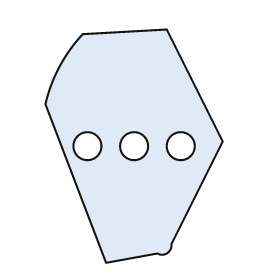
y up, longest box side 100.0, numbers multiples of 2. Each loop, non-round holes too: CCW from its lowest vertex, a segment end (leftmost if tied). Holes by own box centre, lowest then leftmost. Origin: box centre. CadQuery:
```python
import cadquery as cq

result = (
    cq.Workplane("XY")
    .moveTo(-12.0, -50.0)
    .lineTo(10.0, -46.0)
    .threePointArc((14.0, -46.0), (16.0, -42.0))
    .lineTo(38.0, 2.0)
    .lineTo(14.0, 50.0)
    .lineTo(-22.0, 48.0)
    .threePointArc((-32.0, 34.0), (-38.0, 18.0))
    .close()
    .moveTo(-20.0, 0.0)
    .circle(6.0)
    .moveTo(0.0, 0.0)
    .circle(6.0)
    .moveTo(20.0, 0.0)
    .circle(6.0)
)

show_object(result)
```